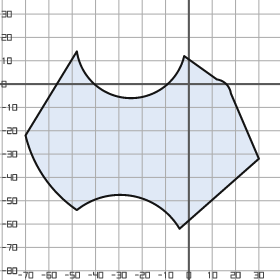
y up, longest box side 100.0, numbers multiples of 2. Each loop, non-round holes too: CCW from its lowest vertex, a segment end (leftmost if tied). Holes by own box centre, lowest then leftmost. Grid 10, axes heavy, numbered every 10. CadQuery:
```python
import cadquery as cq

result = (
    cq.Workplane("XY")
    .moveTo(-4.0, -62.0)
    .lineTo(30.0, -32.0)
    .lineTo(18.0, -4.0)
    .threePointArc((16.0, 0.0), (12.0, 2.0))
    .lineTo(-2.0, 12.0)
    .threePointArc((-26.0, -6.0), (-48.0, 14.0))
    .lineTo(-70.0, -22.0)
    .threePointArc((-62.0, -40.0), (-48.0, -54.0))
    .threePointArc((-24.0, -48.0), (-4.0, -62.0))
    .close()
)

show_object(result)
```